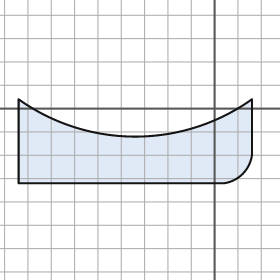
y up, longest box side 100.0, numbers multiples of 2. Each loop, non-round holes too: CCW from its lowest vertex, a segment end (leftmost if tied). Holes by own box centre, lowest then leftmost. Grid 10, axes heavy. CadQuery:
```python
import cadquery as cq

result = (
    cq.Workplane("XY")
    .moveTo(-84.0, -32.0)
    .lineTo(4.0, -32.0)
    .threePointArc((12.0, -28.0), (16.0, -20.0))
    .lineTo(16.0, 4.0)
    .threePointArc((-34.0, -12.0), (-84.0, 4.0))
    .close()
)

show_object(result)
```